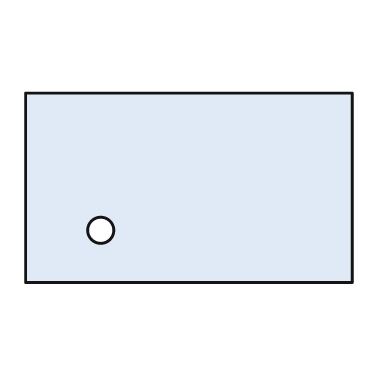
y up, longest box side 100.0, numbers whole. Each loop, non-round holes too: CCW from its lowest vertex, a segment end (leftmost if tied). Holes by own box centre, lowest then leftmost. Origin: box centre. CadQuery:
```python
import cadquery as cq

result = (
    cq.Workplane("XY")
    .moveTo(-50.0, -29.0)
    .lineTo(50.0, -29.0)
    .lineTo(50.0, 29.0)
    .lineTo(-50.0, 29.0)
    .close()
    .moveTo(-27.0, -13.0)
    .circle(4.0)
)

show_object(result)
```